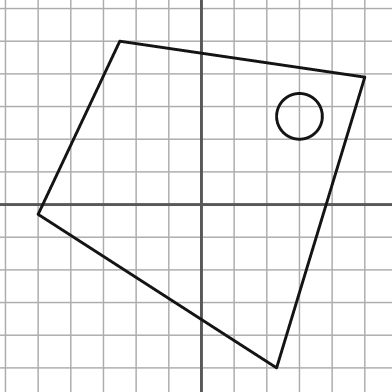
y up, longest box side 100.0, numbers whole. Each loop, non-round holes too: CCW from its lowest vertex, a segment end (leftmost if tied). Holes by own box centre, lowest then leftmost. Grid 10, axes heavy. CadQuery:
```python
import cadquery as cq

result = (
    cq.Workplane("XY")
    .moveTo(23.0, -50.0)
    .lineTo(50.0, 39.0)
    .lineTo(-25.0, 50.0)
    .lineTo(-50.0, -3.0)
    .close()
    .moveTo(30.0, 27.0)
    .circle(7.0)
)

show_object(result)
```